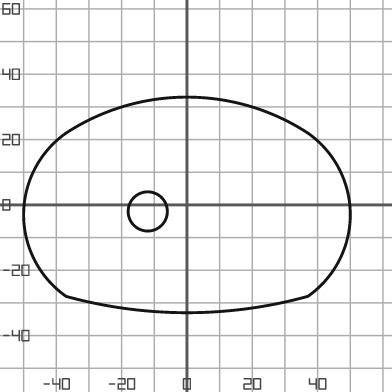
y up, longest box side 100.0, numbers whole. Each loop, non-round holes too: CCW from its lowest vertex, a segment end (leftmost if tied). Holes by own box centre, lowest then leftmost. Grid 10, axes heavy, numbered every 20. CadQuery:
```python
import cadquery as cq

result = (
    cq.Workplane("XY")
    .moveTo(-37.0, -28.0)
    .threePointArc((0.0, -33.0), (37.0, -28.0))
    .threePointArc((50.0, -3.0), (37.0, 22.0))
    .threePointArc((0.0, 33.0), (-37.0, 22.0))
    .threePointArc((-50.0, -3.0), (-37.0, -28.0))
    .close()
    .moveTo(-12.0, -2.0)
    .circle(6.0)
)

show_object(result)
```